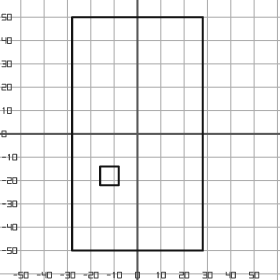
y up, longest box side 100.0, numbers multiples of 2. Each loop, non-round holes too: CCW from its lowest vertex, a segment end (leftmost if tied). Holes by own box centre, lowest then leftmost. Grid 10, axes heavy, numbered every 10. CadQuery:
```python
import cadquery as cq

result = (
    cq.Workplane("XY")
    .moveTo(-28.0, -50.0)
    .lineTo(28.0, -50.0)
    .lineTo(28.0, 50.0)
    .lineTo(-28.0, 50.0)
    .close()
    .moveTo(-16.0, -22.0)
    .lineTo(-8.0, -22.0)
    .lineTo(-8.0, -14.0)
    .lineTo(-16.0, -14.0)
    .close()
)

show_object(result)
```